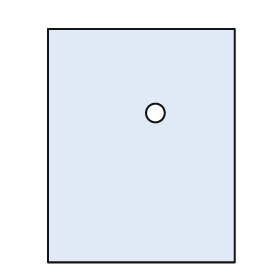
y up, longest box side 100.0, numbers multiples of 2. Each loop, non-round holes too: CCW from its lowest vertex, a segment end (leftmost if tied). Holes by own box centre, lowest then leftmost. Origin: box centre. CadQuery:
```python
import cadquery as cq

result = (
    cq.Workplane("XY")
    .moveTo(-40.0, -50.0)
    .lineTo(40.0, -50.0)
    .lineTo(40.0, 50.0)
    .lineTo(-40.0, 50.0)
    .close()
    .moveTo(6.0, 14.0)
    .circle(4.0)
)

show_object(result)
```